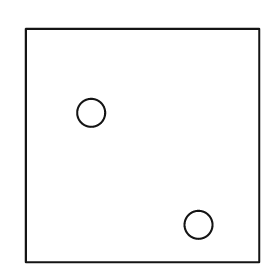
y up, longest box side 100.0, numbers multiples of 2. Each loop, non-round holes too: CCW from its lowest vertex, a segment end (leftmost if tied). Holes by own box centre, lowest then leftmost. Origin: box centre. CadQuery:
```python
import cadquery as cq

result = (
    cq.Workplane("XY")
    .moveTo(-50.0, -50.0)
    .lineTo(50.0, -50.0)
    .lineTo(50.0, 50.0)
    .lineTo(-50.0, 50.0)
    .close()
    .moveTo(24.0, -34.0)
    .circle(6.0)
    .moveTo(-22.0, 14.0)
    .circle(6.0)
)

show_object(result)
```